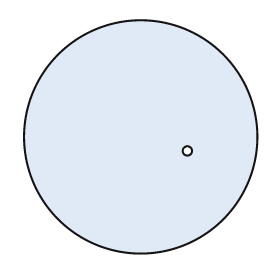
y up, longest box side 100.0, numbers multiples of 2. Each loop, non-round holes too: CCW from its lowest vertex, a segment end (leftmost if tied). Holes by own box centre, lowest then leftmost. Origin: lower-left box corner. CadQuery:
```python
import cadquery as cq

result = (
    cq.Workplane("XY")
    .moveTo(50.0, 50.0)
    .circle(50.0)
    .moveTo(70.0, 44.0)
    .circle(2.0)
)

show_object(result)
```